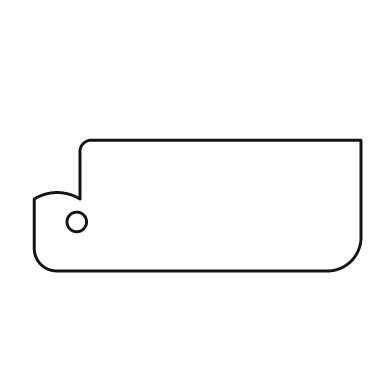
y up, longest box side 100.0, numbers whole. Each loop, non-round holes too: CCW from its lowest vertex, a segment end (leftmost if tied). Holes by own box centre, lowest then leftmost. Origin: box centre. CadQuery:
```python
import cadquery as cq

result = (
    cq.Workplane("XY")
    .moveTo(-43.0, -20.0)
    .lineTo(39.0, -20.0)
    .threePointArc((47.0, -17.0), (50.0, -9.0))
    .lineTo(50.0, 20.0)
    .lineTo(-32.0, 20.0)
    .threePointArc((-35.0, 19.0), (-36.0, 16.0))
    .lineTo(-36.0, 2.0)
    .threePointArc((-43.0, 4.0), (-50.0, 2.0))
    .lineTo(-50.0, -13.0)
    .threePointArc((-48.0, -18.0), (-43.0, -20.0))
    .close()
    .moveTo(-37.0, -5.0)
    .circle(3.0)
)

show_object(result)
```